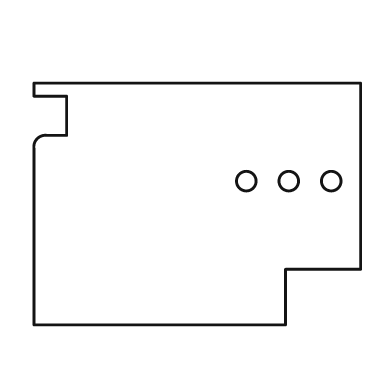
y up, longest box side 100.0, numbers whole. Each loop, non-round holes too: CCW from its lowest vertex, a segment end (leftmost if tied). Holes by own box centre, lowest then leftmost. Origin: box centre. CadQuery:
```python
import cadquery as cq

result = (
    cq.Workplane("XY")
    .moveTo(-50.0, -37.0)
    .lineTo(27.0, -37.0)
    .lineTo(27.0, -20.0)
    .lineTo(50.0, -20.0)
    .lineTo(50.0, 37.0)
    .lineTo(-50.0, 37.0)
    .lineTo(-50.0, 33.0)
    .lineTo(-40.0, 33.0)
    .lineTo(-40.0, 21.0)
    .lineTo(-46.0, 21.0)
    .threePointArc((-49.0, 20.0), (-50.0, 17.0))
    .close()
    .moveTo(15.0, 7.0)
    .circle(3.0)
    .moveTo(28.0, 7.0)
    .circle(3.0)
    .moveTo(41.0, 7.0)
    .circle(3.0)
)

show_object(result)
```